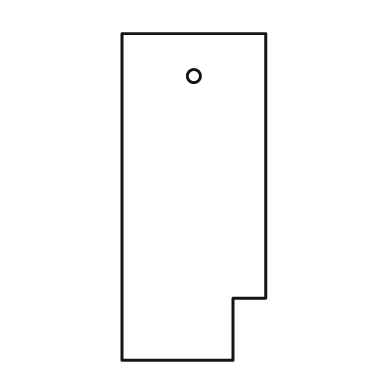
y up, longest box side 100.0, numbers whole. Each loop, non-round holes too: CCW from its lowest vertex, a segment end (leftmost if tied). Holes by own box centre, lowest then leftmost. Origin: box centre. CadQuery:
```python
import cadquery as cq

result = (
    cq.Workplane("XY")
    .moveTo(-22.0, -50.0)
    .lineTo(12.0, -50.0)
    .lineTo(12.0, -31.0)
    .lineTo(22.0, -31.0)
    .lineTo(22.0, 50.0)
    .lineTo(-22.0, 50.0)
    .close()
    .moveTo(0.0, 37.0)
    .circle(2.0)
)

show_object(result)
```